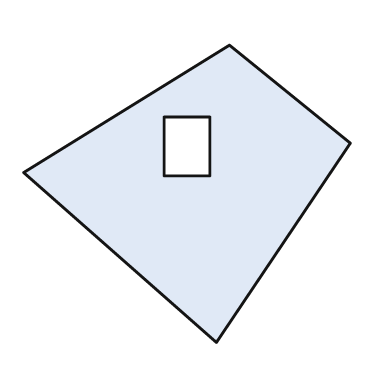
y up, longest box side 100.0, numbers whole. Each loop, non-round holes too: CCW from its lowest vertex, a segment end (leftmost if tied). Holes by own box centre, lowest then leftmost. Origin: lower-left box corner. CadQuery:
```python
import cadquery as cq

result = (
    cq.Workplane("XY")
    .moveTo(59.0, 0.0)
    .lineTo(100.0, 61.0)
    .lineTo(63.0, 91.0)
    .lineTo(0.0, 52.0)
    .close()
    .moveTo(43.0, 51.0)
    .lineTo(57.0, 51.0)
    .lineTo(57.0, 69.0)
    .lineTo(43.0, 69.0)
    .close()
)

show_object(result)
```